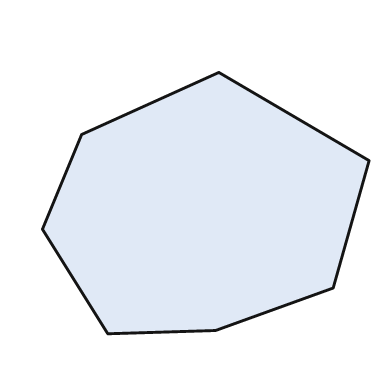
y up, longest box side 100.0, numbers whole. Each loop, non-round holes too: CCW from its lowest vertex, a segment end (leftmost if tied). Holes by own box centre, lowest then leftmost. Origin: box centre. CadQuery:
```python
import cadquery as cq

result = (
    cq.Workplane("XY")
    .moveTo(-30.0, -40.0)
    .lineTo(3.0, -39.0)
    .lineTo(39.0, -26.0)
    .lineTo(50.0, 13.0)
    .lineTo(4.0, 40.0)
    .lineTo(-38.0, 21.0)
    .lineTo(-50.0, -8.0)
    .close()
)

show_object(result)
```